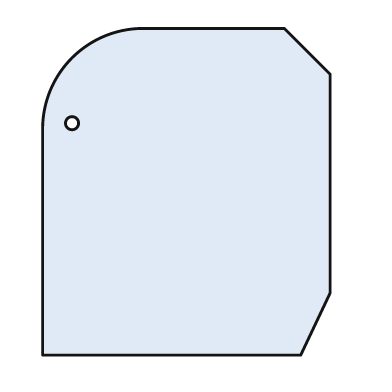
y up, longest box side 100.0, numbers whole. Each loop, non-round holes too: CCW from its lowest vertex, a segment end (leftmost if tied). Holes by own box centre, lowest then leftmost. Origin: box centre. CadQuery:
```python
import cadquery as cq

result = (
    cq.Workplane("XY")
    .moveTo(-44.0, -50.0)
    .lineTo(35.0, -50.0)
    .lineTo(44.0, -31.0)
    .lineTo(44.0, 36.0)
    .lineTo(30.0, 50.0)
    .lineTo(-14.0, 50.0)
    .threePointArc((-35.0, 41.0), (-44.0, 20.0))
    .close()
    .moveTo(-35.0, 21.0)
    .circle(2.0)
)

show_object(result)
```